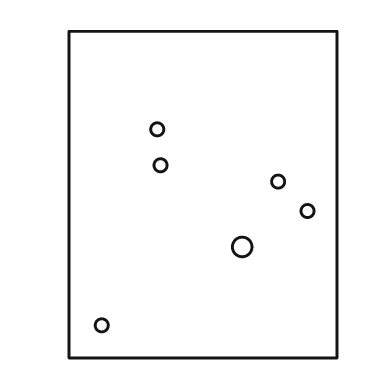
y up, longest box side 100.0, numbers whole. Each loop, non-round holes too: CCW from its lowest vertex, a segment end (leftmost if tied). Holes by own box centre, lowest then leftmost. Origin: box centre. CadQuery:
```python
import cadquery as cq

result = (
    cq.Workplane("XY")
    .moveTo(-41.0, -50.0)
    .lineTo(41.0, -50.0)
    .lineTo(41.0, 50.0)
    .lineTo(-41.0, 50.0)
    .close()
    .moveTo(-31.0, -40.0)
    .circle(2.0)
    .moveTo(12.0, -16.0)
    .circle(3.0)
    .moveTo(32.0, -5.0)
    .circle(2.0)
    .moveTo(23.0, 4.0)
    .circle(2.0)
    .moveTo(-13.0, 9.0)
    .circle(2.0)
    .moveTo(-14.0, 20.0)
    .circle(2.0)
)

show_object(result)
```